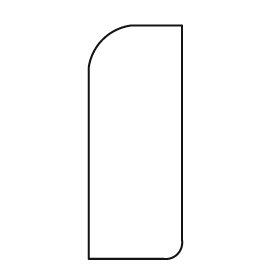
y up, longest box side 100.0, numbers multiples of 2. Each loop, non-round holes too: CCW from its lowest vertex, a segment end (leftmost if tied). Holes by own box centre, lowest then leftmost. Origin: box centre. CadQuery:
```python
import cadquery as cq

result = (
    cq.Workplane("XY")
    .moveTo(-20.0, -50.0)
    .lineTo(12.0, -50.0)
    .threePointArc((18.0, -48.0), (20.0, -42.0))
    .lineTo(20.0, 50.0)
    .lineTo(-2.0, 50.0)
    .threePointArc((-14.0, 44.0), (-20.0, 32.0))
    .close()
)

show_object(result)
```